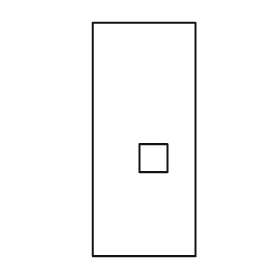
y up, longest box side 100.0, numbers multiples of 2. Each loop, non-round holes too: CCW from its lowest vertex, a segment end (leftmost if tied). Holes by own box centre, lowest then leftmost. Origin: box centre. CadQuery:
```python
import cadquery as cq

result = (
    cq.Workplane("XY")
    .moveTo(-22.0, -50.0)
    .lineTo(22.0, -50.0)
    .lineTo(22.0, 50.0)
    .lineTo(-22.0, 50.0)
    .close()
    .moveTo(-2.0, -14.0)
    .lineTo(10.0, -14.0)
    .lineTo(10.0, -2.0)
    .lineTo(-2.0, -2.0)
    .close()
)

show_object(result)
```